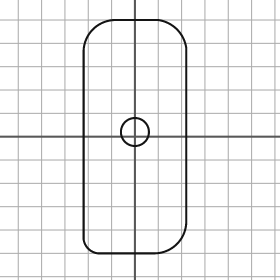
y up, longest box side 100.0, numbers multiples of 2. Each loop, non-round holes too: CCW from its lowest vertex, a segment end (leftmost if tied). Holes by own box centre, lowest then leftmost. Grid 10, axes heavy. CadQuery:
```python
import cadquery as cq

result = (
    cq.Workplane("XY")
    .moveTo(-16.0, -50.0)
    .lineTo(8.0, -50.0)
    .threePointArc((18.0, -46.0), (22.0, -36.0))
    .lineTo(22.0, 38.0)
    .threePointArc((18.0, 46.0), (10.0, 50.0))
    .lineTo(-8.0, 50.0)
    .threePointArc((-18.0, 46.0), (-22.0, 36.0))
    .lineTo(-22.0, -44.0)
    .threePointArc((-20.0, -48.0), (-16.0, -50.0))
    .close()
    .moveTo(0.0, 2.0)
    .circle(6.0)
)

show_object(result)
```